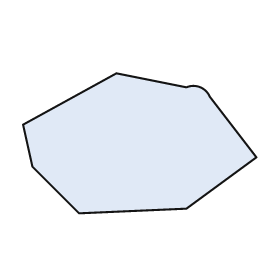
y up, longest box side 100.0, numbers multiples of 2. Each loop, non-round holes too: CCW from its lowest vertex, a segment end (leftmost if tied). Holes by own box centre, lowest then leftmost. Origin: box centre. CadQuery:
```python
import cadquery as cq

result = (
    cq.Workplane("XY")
    .moveTo(-26.0, -30.0)
    .lineTo(20.0, -28.0)
    .lineTo(50.0, -6.0)
    .lineTo(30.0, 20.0)
    .threePointArc((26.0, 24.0), (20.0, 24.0))
    .lineTo(-10.0, 30.0)
    .lineTo(-50.0, 8.0)
    .lineTo(-46.0, -10.0)
    .close()
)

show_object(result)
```